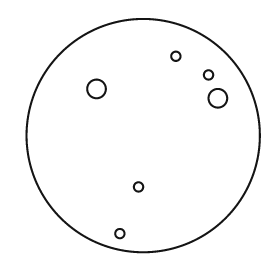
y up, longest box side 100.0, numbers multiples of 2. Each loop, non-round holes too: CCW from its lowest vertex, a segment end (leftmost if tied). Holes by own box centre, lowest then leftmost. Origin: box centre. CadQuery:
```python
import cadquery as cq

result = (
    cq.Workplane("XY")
    .moveTo(0.0, 0.0)
    .circle(50.0)
    .moveTo(-10.0, -42.0)
    .circle(2.0)
    .moveTo(-2.0, -22.0)
    .circle(2.0)
    .moveTo(32.0, 16.0)
    .circle(4.0)
    .moveTo(-20.0, 20.0)
    .circle(4.0)
    .moveTo(28.0, 26.0)
    .circle(2.0)
    .moveTo(14.0, 34.0)
    .circle(2.0)
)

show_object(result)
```